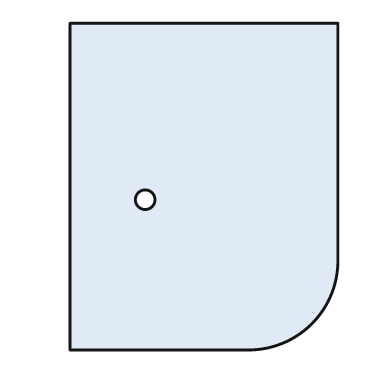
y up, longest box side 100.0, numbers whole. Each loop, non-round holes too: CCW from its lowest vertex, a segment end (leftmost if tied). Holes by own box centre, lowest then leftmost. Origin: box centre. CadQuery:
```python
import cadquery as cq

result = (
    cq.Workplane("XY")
    .moveTo(-41.0, -50.0)
    .lineTo(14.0, -50.0)
    .threePointArc((33.0, -42.0), (41.0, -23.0))
    .lineTo(41.0, 50.0)
    .lineTo(-41.0, 50.0)
    .close()
    .moveTo(-18.0, -4.0)
    .circle(3.0)
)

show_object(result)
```